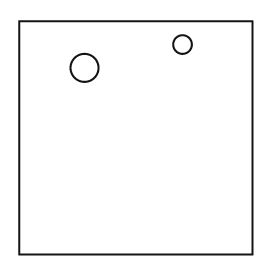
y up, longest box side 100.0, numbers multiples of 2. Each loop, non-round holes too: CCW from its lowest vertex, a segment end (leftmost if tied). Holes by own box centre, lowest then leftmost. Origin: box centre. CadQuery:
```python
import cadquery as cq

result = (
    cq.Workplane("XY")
    .moveTo(-50.0, -50.0)
    .lineTo(50.0, -50.0)
    .lineTo(50.0, 50.0)
    .lineTo(-50.0, 50.0)
    .close()
    .moveTo(-22.0, 30.0)
    .circle(6.0)
    .moveTo(20.0, 40.0)
    .circle(4.0)
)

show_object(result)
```